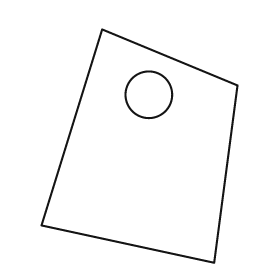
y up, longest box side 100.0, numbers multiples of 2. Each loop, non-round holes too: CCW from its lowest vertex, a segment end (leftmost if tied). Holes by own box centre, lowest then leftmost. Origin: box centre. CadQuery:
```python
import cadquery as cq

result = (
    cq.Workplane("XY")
    .moveTo(32.0, -50.0)
    .lineTo(42.0, 26.0)
    .lineTo(-16.0, 50.0)
    .lineTo(-42.0, -34.0)
    .close()
    .moveTo(4.0, 22.0)
    .circle(10.0)
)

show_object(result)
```